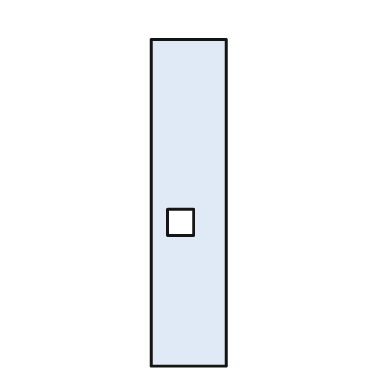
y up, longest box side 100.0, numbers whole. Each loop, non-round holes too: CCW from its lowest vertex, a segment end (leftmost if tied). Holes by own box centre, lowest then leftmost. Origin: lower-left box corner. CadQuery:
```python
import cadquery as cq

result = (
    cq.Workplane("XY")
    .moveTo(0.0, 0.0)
    .lineTo(23.0, 0.0)
    .lineTo(23.0, 100.0)
    .lineTo(0.0, 100.0)
    .close()
    .moveTo(5.0, 40.0)
    .lineTo(13.0, 40.0)
    .lineTo(13.0, 48.0)
    .lineTo(5.0, 48.0)
    .close()
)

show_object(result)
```